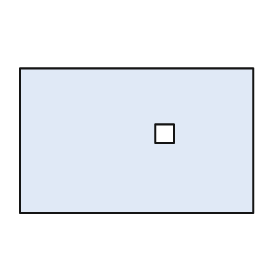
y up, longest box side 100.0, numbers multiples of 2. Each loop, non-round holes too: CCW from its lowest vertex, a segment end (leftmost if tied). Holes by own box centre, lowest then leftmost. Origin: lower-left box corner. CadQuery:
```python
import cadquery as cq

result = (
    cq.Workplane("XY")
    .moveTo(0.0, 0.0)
    .lineTo(100.0, 0.0)
    .lineTo(100.0, 62.0)
    .lineTo(0.0, 62.0)
    .close()
    .moveTo(58.0, 30.0)
    .lineTo(66.0, 30.0)
    .lineTo(66.0, 38.0)
    .lineTo(58.0, 38.0)
    .close()
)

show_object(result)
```